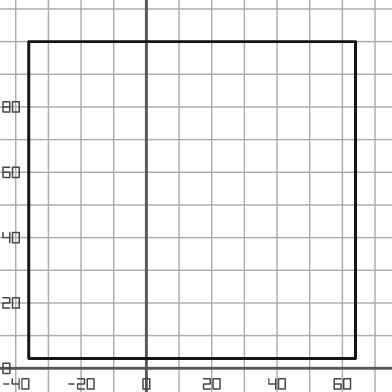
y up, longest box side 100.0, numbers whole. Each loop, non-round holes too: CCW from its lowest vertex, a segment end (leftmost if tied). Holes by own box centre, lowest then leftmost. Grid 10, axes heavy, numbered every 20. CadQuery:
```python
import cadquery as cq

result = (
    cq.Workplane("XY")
    .moveTo(-36.0, 3.0)
    .lineTo(64.0, 3.0)
    .lineTo(64.0, 100.0)
    .lineTo(-36.0, 100.0)
    .close()
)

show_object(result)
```